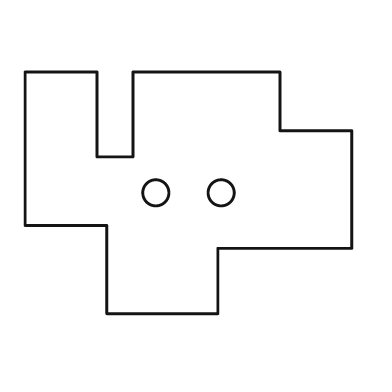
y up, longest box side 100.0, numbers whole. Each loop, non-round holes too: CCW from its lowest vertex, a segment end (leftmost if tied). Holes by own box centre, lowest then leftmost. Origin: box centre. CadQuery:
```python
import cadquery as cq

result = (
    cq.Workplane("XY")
    .moveTo(-25.0, -37.0)
    .lineTo(9.0, -37.0)
    .lineTo(9.0, -17.0)
    .lineTo(50.0, -17.0)
    .lineTo(50.0, 19.0)
    .lineTo(28.0, 19.0)
    .lineTo(28.0, 37.0)
    .lineTo(-17.0, 37.0)
    .lineTo(-17.0, 11.0)
    .lineTo(-28.0, 11.0)
    .lineTo(-28.0, 37.0)
    .lineTo(-50.0, 37.0)
    .lineTo(-50.0, -10.0)
    .lineTo(-25.0, -10.0)
    .close()
    .moveTo(-10.0, 0.0)
    .circle(4.0)
    .moveTo(10.0, 0.0)
    .circle(4.0)
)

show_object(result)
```